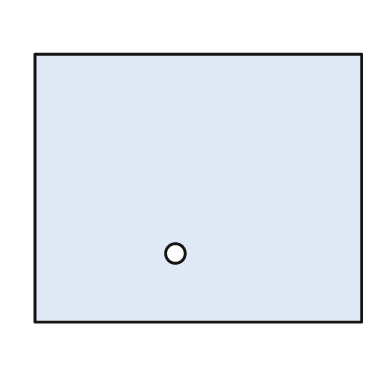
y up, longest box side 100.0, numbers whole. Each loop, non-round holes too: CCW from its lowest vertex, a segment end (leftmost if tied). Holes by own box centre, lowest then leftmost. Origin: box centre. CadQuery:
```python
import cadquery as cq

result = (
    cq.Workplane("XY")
    .moveTo(-50.0, -41.0)
    .lineTo(50.0, -41.0)
    .lineTo(50.0, 41.0)
    .lineTo(-50.0, 41.0)
    .close()
    .moveTo(-7.0, -20.0)
    .circle(3.0)
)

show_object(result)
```